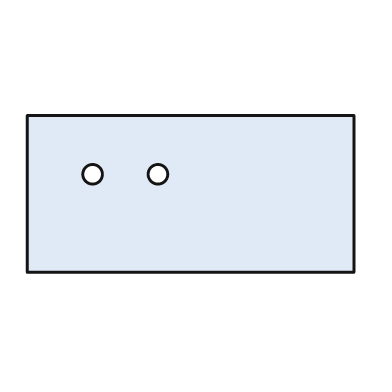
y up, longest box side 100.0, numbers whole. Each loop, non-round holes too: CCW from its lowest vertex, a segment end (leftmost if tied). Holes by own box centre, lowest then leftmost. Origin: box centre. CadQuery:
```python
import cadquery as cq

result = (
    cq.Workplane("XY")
    .moveTo(-50.0, -24.0)
    .lineTo(50.0, -24.0)
    .lineTo(50.0, 24.0)
    .lineTo(-50.0, 24.0)
    .close()
    .moveTo(-30.0, 6.0)
    .circle(3.0)
    .moveTo(-10.0, 6.0)
    .circle(3.0)
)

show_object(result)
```